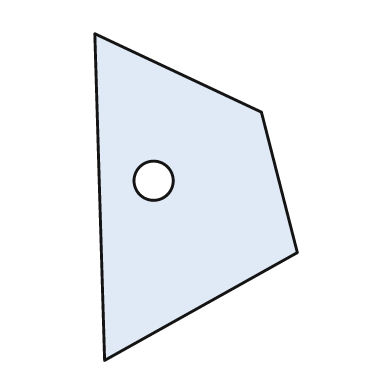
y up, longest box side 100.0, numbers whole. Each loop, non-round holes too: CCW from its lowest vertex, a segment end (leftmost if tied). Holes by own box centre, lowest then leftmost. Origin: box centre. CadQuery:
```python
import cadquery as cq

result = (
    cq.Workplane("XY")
    .moveTo(-28.0, -50.0)
    .lineTo(31.0, -17.0)
    .lineTo(20.0, 26.0)
    .lineTo(-31.0, 50.0)
    .close()
    .moveTo(-13.0, 5.0)
    .circle(6.0)
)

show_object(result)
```